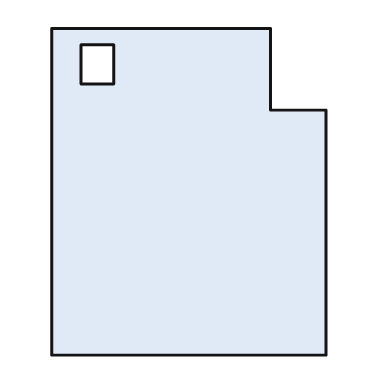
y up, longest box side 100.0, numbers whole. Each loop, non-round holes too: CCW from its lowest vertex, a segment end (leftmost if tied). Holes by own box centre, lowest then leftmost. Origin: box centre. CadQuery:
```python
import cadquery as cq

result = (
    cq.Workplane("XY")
    .moveTo(-42.0, -50.0)
    .lineTo(42.0, -50.0)
    .lineTo(42.0, 25.0)
    .lineTo(25.0, 25.0)
    .lineTo(25.0, 50.0)
    .lineTo(-42.0, 50.0)
    .close()
    .moveTo(-33.0, 33.0)
    .lineTo(-23.0, 33.0)
    .lineTo(-23.0, 45.0)
    .lineTo(-33.0, 45.0)
    .close()
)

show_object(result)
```